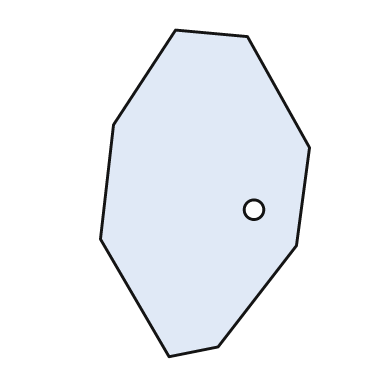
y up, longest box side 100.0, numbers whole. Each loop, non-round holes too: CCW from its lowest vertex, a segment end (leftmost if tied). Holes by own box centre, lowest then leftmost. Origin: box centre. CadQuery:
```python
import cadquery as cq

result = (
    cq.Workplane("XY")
    .moveTo(-11.0, -50.0)
    .lineTo(4.0, -47.0)
    .lineTo(28.0, -16.0)
    .lineTo(32.0, 14.0)
    .lineTo(13.0, 48.0)
    .lineTo(-9.0, 50.0)
    .lineTo(-28.0, 21.0)
    .lineTo(-32.0, -14.0)
    .close()
    .moveTo(15.0, -5.0)
    .circle(3.0)
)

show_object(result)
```